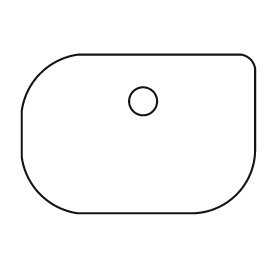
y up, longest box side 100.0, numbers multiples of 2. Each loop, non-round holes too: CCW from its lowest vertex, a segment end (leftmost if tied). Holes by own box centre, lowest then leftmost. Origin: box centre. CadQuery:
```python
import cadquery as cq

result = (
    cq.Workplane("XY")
    .moveTo(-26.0, -34.0)
    .lineTo(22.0, -34.0)
    .threePointArc((42.0, -26.0), (50.0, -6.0))
    .lineTo(50.0, 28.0)
    .threePointArc((48.0, 32.0), (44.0, 34.0))
    .lineTo(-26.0, 34.0)
    .threePointArc((-42.0, 26.0), (-50.0, 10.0))
    .lineTo(-50.0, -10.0)
    .threePointArc((-42.0, -26.0), (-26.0, -34.0))
    .close()
    .moveTo(2.0, 14.0)
    .circle(6.0)
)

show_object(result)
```